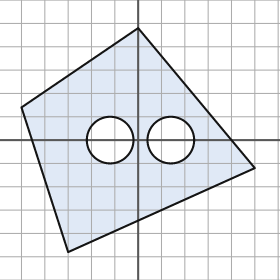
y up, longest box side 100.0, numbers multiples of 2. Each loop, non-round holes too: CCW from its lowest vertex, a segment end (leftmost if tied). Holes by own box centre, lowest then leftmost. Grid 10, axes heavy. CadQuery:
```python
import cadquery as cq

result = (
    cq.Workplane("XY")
    .moveTo(-30.0, -48.0)
    .lineTo(50.0, -12.0)
    .lineTo(0.0, 48.0)
    .lineTo(-50.0, 14.0)
    .close()
    .moveTo(-12.0, 0.0)
    .circle(10.0)
    .moveTo(14.0, 0.0)
    .circle(10.0)
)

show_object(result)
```